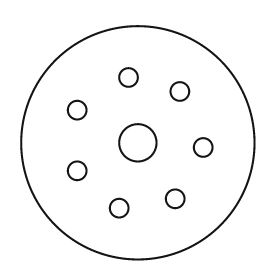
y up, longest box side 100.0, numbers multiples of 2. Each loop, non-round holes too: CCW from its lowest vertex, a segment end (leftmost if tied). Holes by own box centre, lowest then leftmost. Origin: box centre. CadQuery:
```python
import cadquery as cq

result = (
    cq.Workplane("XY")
    .moveTo(0.0, 0.0)
    .circle(50.0)
    .moveTo(-8.0, -28.0)
    .circle(4.0)
    .moveTo(16.0, -24.0)
    .circle(4.0)
    .moveTo(-26.0, -12.0)
    .circle(4.0)
    .moveTo(28.0, -2.0)
    .circle(4.0)
    .moveTo(0.0, 0.0)
    .circle(8.0)
    .moveTo(-26.0, 14.0)
    .circle(4.0)
    .moveTo(18.0, 22.0)
    .circle(4.0)
    .moveTo(-4.0, 28.0)
    .circle(4.0)
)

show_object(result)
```